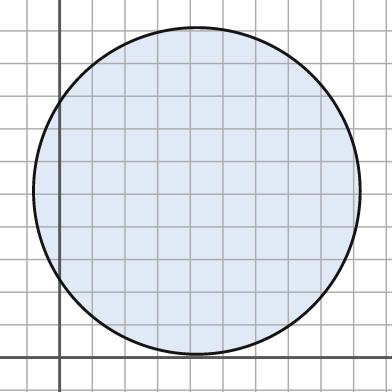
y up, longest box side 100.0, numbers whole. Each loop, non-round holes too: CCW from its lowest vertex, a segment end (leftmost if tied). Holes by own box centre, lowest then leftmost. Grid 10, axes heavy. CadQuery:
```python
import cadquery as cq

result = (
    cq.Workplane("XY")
    .moveTo(42.0, 51.0)
    .circle(50.0)
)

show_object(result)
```